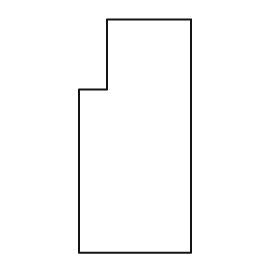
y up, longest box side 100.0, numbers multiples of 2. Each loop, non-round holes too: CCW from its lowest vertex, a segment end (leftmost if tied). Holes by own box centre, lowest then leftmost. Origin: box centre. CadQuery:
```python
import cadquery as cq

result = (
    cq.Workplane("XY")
    .moveTo(-24.0, -50.0)
    .lineTo(24.0, -50.0)
    .lineTo(24.0, 50.0)
    .lineTo(-12.0, 50.0)
    .lineTo(-12.0, 20.0)
    .lineTo(-24.0, 20.0)
    .close()
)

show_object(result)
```